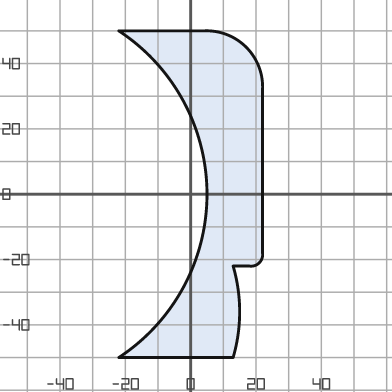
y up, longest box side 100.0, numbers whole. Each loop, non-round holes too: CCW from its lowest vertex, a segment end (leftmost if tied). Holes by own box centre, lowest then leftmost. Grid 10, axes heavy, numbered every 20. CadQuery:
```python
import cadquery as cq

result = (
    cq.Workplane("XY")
    .moveTo(-22.0, -50.0)
    .lineTo(13.0, -50.0)
    .threePointArc((15.0, -36.0), (13.0, -22.0))
    .lineTo(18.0, -22.0)
    .threePointArc((21.0, -21.0), (22.0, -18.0))
    .lineTo(22.0, 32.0)
    .threePointArc((17.0, 45.0), (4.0, 50.0))
    .lineTo(-22.0, 50.0)
    .threePointArc((5.0, 0.0), (-22.0, -50.0))
    .close()
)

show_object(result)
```